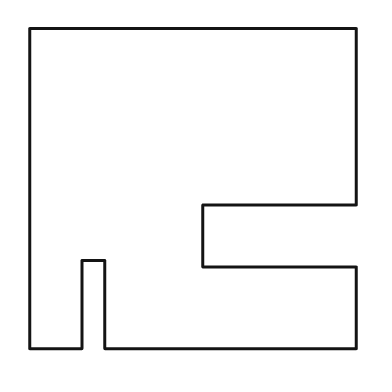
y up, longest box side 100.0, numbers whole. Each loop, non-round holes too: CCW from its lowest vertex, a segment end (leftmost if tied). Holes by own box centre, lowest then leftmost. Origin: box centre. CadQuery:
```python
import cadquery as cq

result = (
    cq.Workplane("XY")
    .moveTo(-50.0, -49.0)
    .lineTo(-34.0, -49.0)
    .lineTo(-34.0, -22.0)
    .lineTo(-27.0, -22.0)
    .lineTo(-27.0, -49.0)
    .lineTo(50.0, -49.0)
    .lineTo(50.0, -24.0)
    .lineTo(3.0, -24.0)
    .lineTo(3.0, -5.0)
    .lineTo(50.0, -5.0)
    .lineTo(50.0, 49.0)
    .lineTo(-50.0, 49.0)
    .close()
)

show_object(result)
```